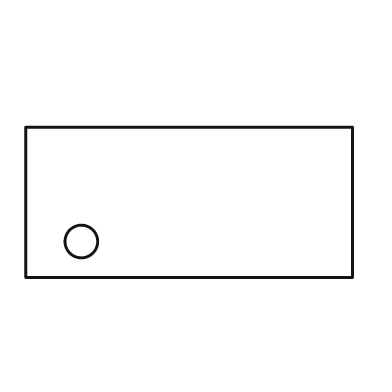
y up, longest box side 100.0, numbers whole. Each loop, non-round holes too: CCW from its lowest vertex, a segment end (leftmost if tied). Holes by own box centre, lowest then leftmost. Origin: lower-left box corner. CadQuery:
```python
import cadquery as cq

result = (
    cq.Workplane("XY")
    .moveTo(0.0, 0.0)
    .lineTo(100.0, 0.0)
    .lineTo(100.0, 46.0)
    .lineTo(0.0, 46.0)
    .close()
    .moveTo(17.0, 11.0)
    .circle(5.0)
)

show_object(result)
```